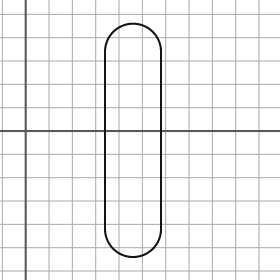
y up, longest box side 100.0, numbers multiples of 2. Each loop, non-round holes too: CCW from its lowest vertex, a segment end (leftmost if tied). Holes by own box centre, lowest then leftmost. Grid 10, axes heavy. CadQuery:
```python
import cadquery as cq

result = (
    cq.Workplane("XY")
    .moveTo(34.0, -42.0)
    .threePointArc((46.0, -54.0), (58.0, -42.0))
    .lineTo(58.0, 34.0)
    .threePointArc((46.0, 46.0), (34.0, 34.0))
    .close()
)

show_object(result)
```